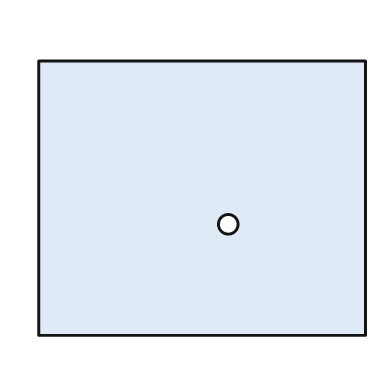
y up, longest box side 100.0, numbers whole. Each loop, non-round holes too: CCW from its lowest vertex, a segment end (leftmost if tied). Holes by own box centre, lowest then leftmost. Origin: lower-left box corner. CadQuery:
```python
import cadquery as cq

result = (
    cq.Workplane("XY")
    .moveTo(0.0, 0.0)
    .lineTo(100.0, 0.0)
    .lineTo(100.0, 84.0)
    .lineTo(0.0, 84.0)
    .close()
    .moveTo(58.0, 34.0)
    .circle(3.0)
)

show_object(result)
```